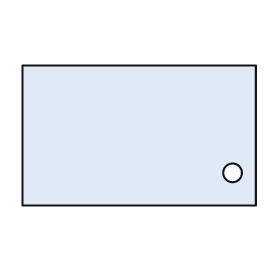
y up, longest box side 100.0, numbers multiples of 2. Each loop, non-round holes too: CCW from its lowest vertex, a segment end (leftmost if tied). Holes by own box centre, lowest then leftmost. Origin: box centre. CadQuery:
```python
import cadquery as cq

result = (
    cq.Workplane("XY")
    .moveTo(-50.0, -30.0)
    .lineTo(50.0, -30.0)
    .lineTo(50.0, 30.0)
    .lineTo(-50.0, 30.0)
    .close()
    .moveTo(40.0, -16.0)
    .circle(4.0)
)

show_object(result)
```